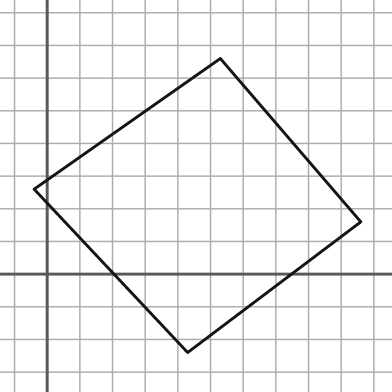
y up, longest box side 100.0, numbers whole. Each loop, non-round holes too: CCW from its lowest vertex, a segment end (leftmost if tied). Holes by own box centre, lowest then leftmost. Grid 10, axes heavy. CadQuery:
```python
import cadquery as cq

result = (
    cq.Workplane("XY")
    .moveTo(43.0, -24.0)
    .lineTo(96.0, 16.0)
    .lineTo(53.0, 66.0)
    .lineTo(-4.0, 26.0)
    .close()
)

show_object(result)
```